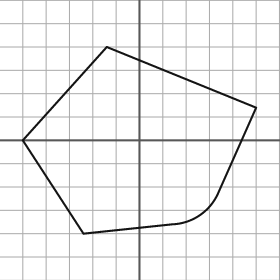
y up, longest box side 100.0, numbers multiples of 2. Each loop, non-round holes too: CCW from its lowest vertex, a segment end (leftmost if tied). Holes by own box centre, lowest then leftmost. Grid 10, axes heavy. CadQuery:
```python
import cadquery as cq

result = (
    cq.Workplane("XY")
    .moveTo(-24.0, -40.0)
    .lineTo(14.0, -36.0)
    .threePointArc((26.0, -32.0), (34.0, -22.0))
    .lineTo(50.0, 14.0)
    .lineTo(-14.0, 40.0)
    .lineTo(-50.0, 0.0)
    .close()
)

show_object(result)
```